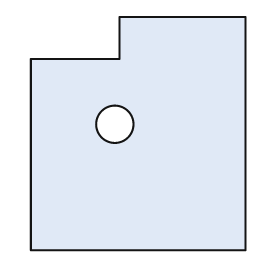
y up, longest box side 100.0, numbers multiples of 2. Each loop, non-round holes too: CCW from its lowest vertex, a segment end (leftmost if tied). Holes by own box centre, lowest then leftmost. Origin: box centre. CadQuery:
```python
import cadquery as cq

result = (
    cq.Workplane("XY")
    .moveTo(-46.0, -50.0)
    .lineTo(46.0, -50.0)
    .lineTo(46.0, 50.0)
    .lineTo(-8.0, 50.0)
    .lineTo(-8.0, 32.0)
    .lineTo(-46.0, 32.0)
    .close()
    .moveTo(-10.0, 4.0)
    .circle(8.0)
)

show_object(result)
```